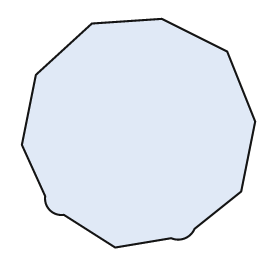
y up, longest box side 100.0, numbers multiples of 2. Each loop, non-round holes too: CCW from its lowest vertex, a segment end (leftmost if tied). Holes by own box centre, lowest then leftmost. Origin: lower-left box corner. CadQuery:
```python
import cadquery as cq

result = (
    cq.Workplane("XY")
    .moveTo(40.0, 0.0)
    .lineTo(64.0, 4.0)
    .threePointArc((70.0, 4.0), (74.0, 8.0))
    .lineTo(94.0, 24.0)
    .lineTo(100.0, 54.0)
    .lineTo(88.0, 84.0)
    .lineTo(60.0, 98.0)
    .lineTo(30.0, 96.0)
    .lineTo(6.0, 74.0)
    .lineTo(0.0, 44.0)
    .lineTo(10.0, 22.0)
    .threePointArc((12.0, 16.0), (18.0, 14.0))
    .close()
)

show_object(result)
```